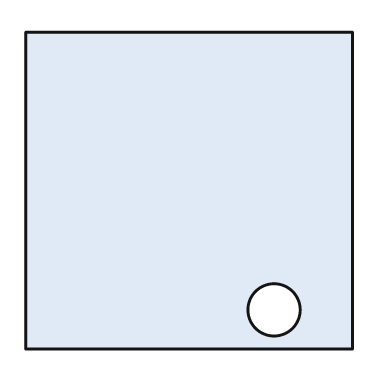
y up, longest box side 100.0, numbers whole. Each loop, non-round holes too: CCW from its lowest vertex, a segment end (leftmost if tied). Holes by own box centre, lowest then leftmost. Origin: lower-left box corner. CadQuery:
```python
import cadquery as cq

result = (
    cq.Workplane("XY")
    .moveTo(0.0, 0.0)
    .lineTo(100.0, 0.0)
    .lineTo(100.0, 97.0)
    .lineTo(0.0, 97.0)
    .close()
    .moveTo(76.0, 12.0)
    .circle(8.0)
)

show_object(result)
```